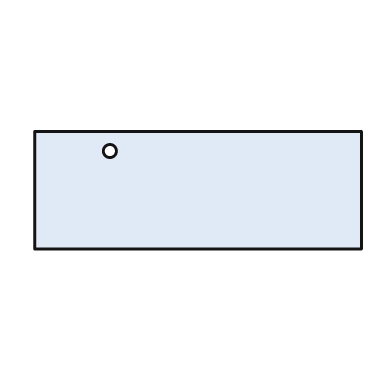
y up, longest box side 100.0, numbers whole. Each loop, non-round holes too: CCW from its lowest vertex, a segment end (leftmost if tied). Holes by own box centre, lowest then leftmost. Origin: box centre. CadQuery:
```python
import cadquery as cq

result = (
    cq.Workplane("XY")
    .moveTo(-50.0, -18.0)
    .lineTo(50.0, -18.0)
    .lineTo(50.0, 18.0)
    .lineTo(-50.0, 18.0)
    .close()
    .moveTo(-27.0, 12.0)
    .circle(2.0)
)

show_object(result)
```